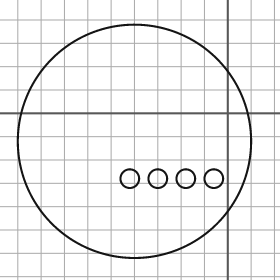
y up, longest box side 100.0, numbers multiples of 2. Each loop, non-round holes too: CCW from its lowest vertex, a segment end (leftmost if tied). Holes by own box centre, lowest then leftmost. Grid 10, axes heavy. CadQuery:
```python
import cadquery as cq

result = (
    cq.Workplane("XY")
    .moveTo(-40.0, -12.0)
    .circle(50.0)
    .moveTo(-42.0, -28.0)
    .circle(4.0)
    .moveTo(-30.0, -28.0)
    .circle(4.0)
    .moveTo(-18.0, -28.0)
    .circle(4.0)
    .moveTo(-6.0, -28.0)
    .circle(4.0)
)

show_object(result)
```